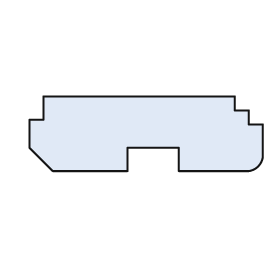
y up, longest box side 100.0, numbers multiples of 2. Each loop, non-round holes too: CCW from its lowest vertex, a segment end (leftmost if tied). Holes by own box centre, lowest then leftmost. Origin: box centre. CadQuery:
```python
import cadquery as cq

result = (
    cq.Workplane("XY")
    .moveTo(-40.0, -16.0)
    .lineTo(-8.0, -16.0)
    .lineTo(-8.0, -6.0)
    .lineTo(14.0, -6.0)
    .lineTo(14.0, -16.0)
    .lineTo(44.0, -16.0)
    .threePointArc((48.0, -14.0), (50.0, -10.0))
    .lineTo(50.0, 4.0)
    .lineTo(44.0, 4.0)
    .lineTo(44.0, 10.0)
    .lineTo(38.0, 10.0)
    .lineTo(38.0, 16.0)
    .lineTo(-44.0, 16.0)
    .lineTo(-44.0, 6.0)
    .lineTo(-50.0, 6.0)
    .lineTo(-50.0, -6.0)
    .close()
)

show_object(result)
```